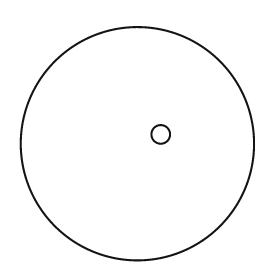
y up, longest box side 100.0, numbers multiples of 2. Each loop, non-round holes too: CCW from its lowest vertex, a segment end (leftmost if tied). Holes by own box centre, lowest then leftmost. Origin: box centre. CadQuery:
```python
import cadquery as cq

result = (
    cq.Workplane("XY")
    .moveTo(0.0, 0.0)
    .circle(50.0)
    .moveTo(10.0, 4.0)
    .circle(4.0)
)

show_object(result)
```